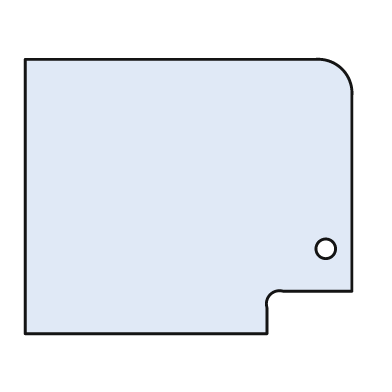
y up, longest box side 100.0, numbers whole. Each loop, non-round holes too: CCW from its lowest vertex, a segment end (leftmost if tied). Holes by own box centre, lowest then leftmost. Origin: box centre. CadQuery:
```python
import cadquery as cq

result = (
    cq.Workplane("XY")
    .moveTo(-50.0, -42.0)
    .lineTo(24.0, -42.0)
    .lineTo(24.0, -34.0)
    .threePointArc((25.0, -30.0), (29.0, -29.0))
    .lineTo(50.0, -29.0)
    .lineTo(50.0, 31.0)
    .threePointArc((47.0, 39.0), (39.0, 42.0))
    .lineTo(-50.0, 42.0)
    .close()
    .moveTo(42.0, -16.0)
    .circle(3.0)
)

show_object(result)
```